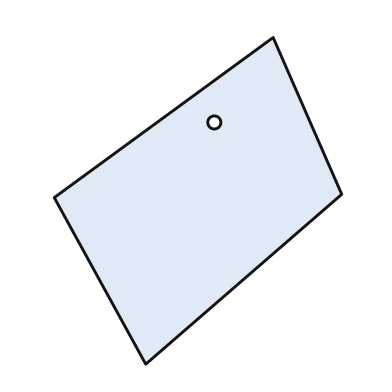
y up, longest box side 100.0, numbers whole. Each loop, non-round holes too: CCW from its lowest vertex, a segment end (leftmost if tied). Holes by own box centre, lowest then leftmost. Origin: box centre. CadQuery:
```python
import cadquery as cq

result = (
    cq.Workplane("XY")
    .moveTo(-16.0, -50.0)
    .lineTo(44.0, 2.0)
    .lineTo(23.0, 50.0)
    .lineTo(-44.0, 1.0)
    .close()
    .moveTo(5.0, 24.0)
    .circle(2.0)
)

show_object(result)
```